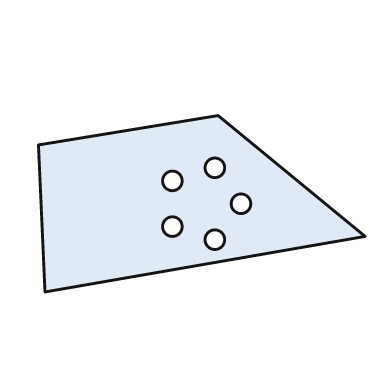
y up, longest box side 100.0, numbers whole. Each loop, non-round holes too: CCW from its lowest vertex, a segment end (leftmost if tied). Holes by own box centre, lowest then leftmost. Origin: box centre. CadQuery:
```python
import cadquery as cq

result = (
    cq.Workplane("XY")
    .moveTo(-48.0, -27.0)
    .lineTo(50.0, -10.0)
    .lineTo(5.0, 27.0)
    .lineTo(-50.0, 18.0)
    .close()
    .moveTo(4.0, -11.0)
    .circle(3.0)
    .moveTo(-9.0, -7.0)
    .circle(3.0)
    .moveTo(12.0, 0.0)
    .circle(3.0)
    .moveTo(-9.0, 7.0)
    .circle(3.0)
    .moveTo(4.0, 11.0)
    .circle(3.0)
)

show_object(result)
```